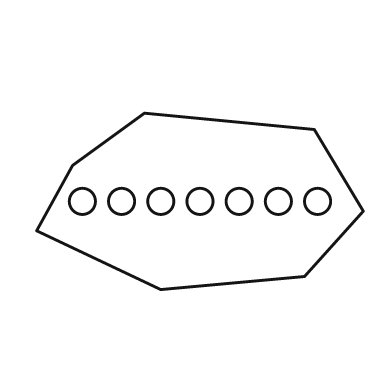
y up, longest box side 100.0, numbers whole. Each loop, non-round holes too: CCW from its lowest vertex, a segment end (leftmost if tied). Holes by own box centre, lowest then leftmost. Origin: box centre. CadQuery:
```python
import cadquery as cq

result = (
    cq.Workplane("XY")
    .moveTo(-12.0, -27.0)
    .lineTo(32.0, -23.0)
    .lineTo(50.0, -3.0)
    .lineTo(35.0, 22.0)
    .lineTo(-17.0, 27.0)
    .lineTo(-39.0, 11.0)
    .lineTo(-50.0, -9.0)
    .close()
    .moveTo(-36.0, 0.0)
    .circle(4.0)
    .moveTo(-24.0, 0.0)
    .circle(4.0)
    .moveTo(-12.0, 0.0)
    .circle(4.0)
    .moveTo(0.0, 0.0)
    .circle(4.0)
    .moveTo(12.0, 0.0)
    .circle(4.0)
    .moveTo(24.0, 0.0)
    .circle(4.0)
    .moveTo(36.0, 0.0)
    .circle(4.0)
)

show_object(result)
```